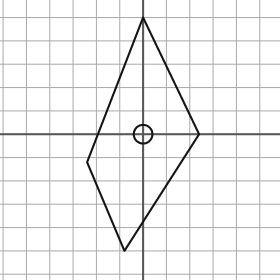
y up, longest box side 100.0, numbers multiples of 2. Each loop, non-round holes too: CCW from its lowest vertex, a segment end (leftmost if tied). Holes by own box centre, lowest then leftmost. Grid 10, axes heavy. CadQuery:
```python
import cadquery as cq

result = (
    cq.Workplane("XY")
    .moveTo(-8.0, -50.0)
    .lineTo(24.0, 0.0)
    .lineTo(0.0, 50.0)
    .lineTo(-24.0, -12.0)
    .close()
    .moveTo(0.0, 0.0)
    .circle(4.0)
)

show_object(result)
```